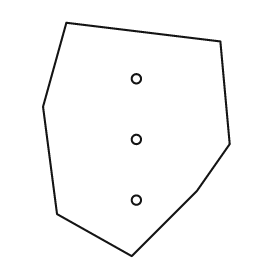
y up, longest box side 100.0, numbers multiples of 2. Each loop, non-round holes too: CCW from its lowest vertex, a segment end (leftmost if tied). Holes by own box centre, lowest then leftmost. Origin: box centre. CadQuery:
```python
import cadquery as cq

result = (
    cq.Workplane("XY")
    .moveTo(-2.0, -50.0)
    .lineTo(26.0, -22.0)
    .lineTo(40.0, -2.0)
    .lineTo(36.0, 42.0)
    .lineTo(-30.0, 50.0)
    .lineTo(-40.0, 14.0)
    .lineTo(-34.0, -32.0)
    .close()
    .moveTo(0.0, -26.0)
    .circle(2.0)
    .moveTo(0.0, 0.0)
    .circle(2.0)
    .moveTo(0.0, 26.0)
    .circle(2.0)
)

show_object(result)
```